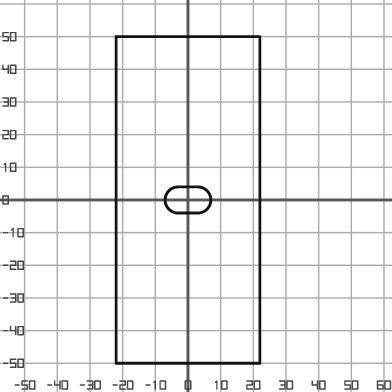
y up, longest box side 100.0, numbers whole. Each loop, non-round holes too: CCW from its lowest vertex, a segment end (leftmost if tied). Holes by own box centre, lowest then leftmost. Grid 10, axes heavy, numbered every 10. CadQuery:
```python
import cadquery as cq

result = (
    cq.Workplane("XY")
    .moveTo(-22.0, -50.0)
    .lineTo(22.0, -50.0)
    .lineTo(22.0, 50.0)
    .lineTo(-22.0, 50.0)
    .close()
    .moveTo(-3.0, -4.0)
    .lineTo(3.0, -4.0)
    .threePointArc((7.0, 0.0), (3.0, 4.0))
    .lineTo(-3.0, 4.0)
    .threePointArc((-7.0, 0.0), (-3.0, -4.0))
    .close()
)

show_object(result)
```